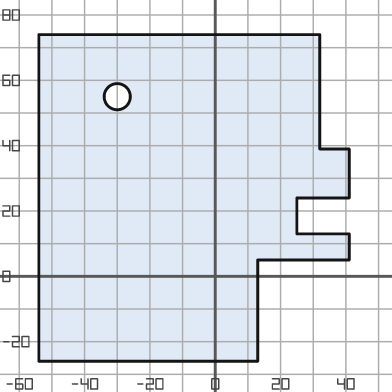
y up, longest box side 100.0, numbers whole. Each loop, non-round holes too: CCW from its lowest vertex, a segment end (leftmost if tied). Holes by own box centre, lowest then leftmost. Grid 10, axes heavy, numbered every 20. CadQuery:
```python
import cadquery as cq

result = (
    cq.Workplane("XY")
    .moveTo(-54.0, -26.0)
    .lineTo(13.0, -26.0)
    .lineTo(13.0, 5.0)
    .lineTo(41.0, 5.0)
    .lineTo(41.0, 13.0)
    .lineTo(25.0, 13.0)
    .lineTo(25.0, 24.0)
    .lineTo(41.0, 24.0)
    .lineTo(41.0, 39.0)
    .lineTo(32.0, 39.0)
    .lineTo(32.0, 74.0)
    .lineTo(-54.0, 74.0)
    .close()
    .moveTo(-30.0, 55.0)
    .circle(4.0)
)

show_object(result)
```